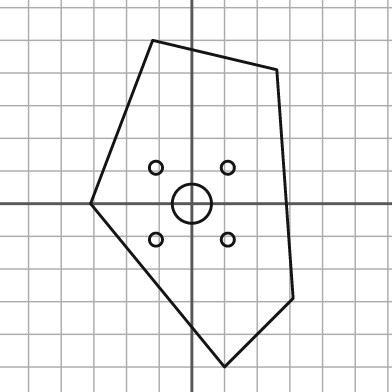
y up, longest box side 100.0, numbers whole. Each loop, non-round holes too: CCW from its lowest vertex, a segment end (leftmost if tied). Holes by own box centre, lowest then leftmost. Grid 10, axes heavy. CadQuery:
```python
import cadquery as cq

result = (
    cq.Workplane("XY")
    .moveTo(10.0, -50.0)
    .lineTo(31.0, -29.0)
    .lineTo(26.0, 41.0)
    .lineTo(-12.0, 50.0)
    .lineTo(-31.0, 0.0)
    .close()
    .moveTo(-11.0, -11.0)
    .circle(2.0)
    .moveTo(11.0, -11.0)
    .circle(2.0)
    .moveTo(0.0, 0.0)
    .circle(6.0)
    .moveTo(-11.0, 11.0)
    .circle(2.0)
    .moveTo(11.0, 11.0)
    .circle(2.0)
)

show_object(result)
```